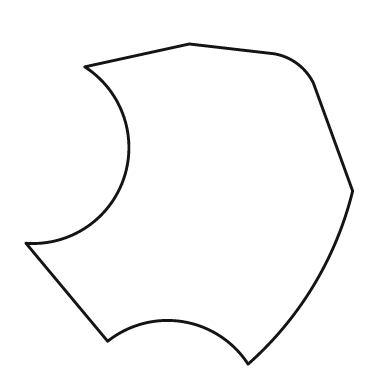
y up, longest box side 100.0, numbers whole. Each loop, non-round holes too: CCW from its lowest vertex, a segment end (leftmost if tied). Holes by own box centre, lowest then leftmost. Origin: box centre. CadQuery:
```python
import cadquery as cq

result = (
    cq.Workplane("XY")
    .moveTo(18.0, -49.0)
    .threePointArc((38.0, -25.0), (50.0, 4.0))
    .lineTo(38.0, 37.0)
    .threePointArc((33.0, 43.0), (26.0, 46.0))
    .lineTo(0.0, 49.0)
    .lineTo(-32.0, 42.0)
    .threePointArc((-20.0, 8.0), (-50.0, -12.0))
    .lineTo(-25.0, -42.0)
    .threePointArc((-2.0, -36.0), (18.0, -49.0))
    .close()
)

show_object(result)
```